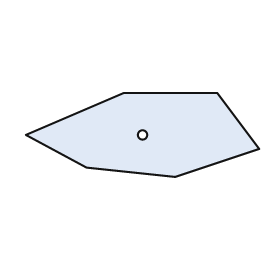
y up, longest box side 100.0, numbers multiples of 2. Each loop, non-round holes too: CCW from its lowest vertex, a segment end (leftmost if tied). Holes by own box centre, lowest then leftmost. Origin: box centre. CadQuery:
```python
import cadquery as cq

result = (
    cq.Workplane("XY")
    .moveTo(14.0, -18.0)
    .lineTo(50.0, -6.0)
    .lineTo(32.0, 18.0)
    .lineTo(-8.0, 18.0)
    .lineTo(-50.0, 0.0)
    .lineTo(-24.0, -14.0)
    .close()
    .moveTo(0.0, 0.0)
    .circle(2.0)
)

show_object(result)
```